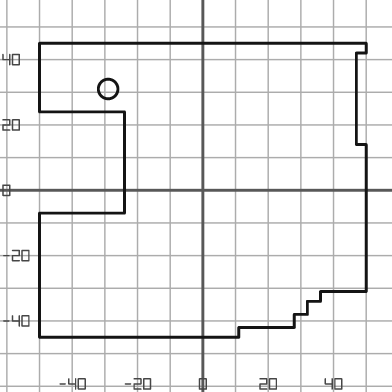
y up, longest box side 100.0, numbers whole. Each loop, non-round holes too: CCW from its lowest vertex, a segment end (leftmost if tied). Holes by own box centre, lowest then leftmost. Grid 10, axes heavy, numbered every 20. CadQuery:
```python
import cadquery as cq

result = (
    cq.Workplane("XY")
    .moveTo(-50.0, -45.0)
    .lineTo(11.0, -45.0)
    .lineTo(11.0, -42.0)
    .lineTo(28.0, -42.0)
    .lineTo(28.0, -38.0)
    .lineTo(32.0, -38.0)
    .lineTo(32.0, -34.0)
    .lineTo(36.0, -34.0)
    .lineTo(36.0, -31.0)
    .lineTo(50.0, -31.0)
    .lineTo(50.0, 14.0)
    .lineTo(47.0, 14.0)
    .lineTo(47.0, 42.0)
    .lineTo(50.0, 42.0)
    .lineTo(50.0, 45.0)
    .lineTo(-50.0, 45.0)
    .lineTo(-50.0, 24.0)
    .lineTo(-24.0, 24.0)
    .lineTo(-24.0, -7.0)
    .lineTo(-50.0, -7.0)
    .close()
    .moveTo(-29.0, 31.0)
    .circle(3.0)
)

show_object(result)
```